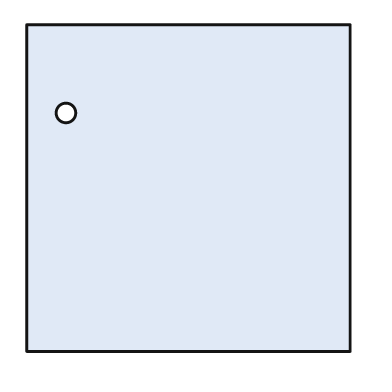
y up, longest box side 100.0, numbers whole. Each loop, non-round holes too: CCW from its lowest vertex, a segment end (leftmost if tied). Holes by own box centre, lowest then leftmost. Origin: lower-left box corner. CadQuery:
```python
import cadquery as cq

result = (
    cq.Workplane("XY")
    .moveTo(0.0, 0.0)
    .lineTo(99.0, 0.0)
    .lineTo(99.0, 100.0)
    .lineTo(0.0, 100.0)
    .close()
    .moveTo(12.0, 73.0)
    .circle(3.0)
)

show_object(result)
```